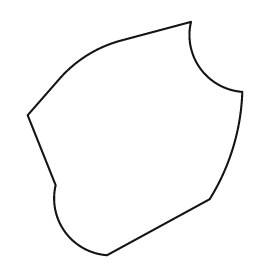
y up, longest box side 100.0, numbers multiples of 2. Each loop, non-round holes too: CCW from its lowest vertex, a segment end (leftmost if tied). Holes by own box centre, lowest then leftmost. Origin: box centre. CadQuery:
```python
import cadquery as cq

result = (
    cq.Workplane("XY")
    .moveTo(-12.0, -50.0)
    .lineTo(32.0, -26.0)
    .threePointArc((42.0, -4.0), (46.0, 20.0))
    .threePointArc((28.0, 30.0), (24.0, 50.0))
    .lineTo(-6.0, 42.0)
    .threePointArc((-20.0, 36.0), (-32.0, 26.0))
    .lineTo(-46.0, 10.0)
    .lineTo(-34.0, -20.0)
    .threePointArc((-30.0, -40.0), (-12.0, -50.0))
    .close()
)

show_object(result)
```